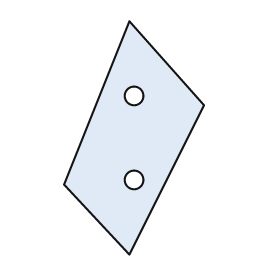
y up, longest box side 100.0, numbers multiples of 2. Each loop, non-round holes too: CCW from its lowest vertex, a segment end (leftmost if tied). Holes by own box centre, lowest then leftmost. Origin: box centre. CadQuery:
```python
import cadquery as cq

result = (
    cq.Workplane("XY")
    .moveTo(-2.0, -50.0)
    .lineTo(30.0, 14.0)
    .lineTo(-2.0, 50.0)
    .lineTo(-30.0, -20.0)
    .close()
    .moveTo(0.0, -18.0)
    .circle(4.0)
    .moveTo(0.0, 18.0)
    .circle(4.0)
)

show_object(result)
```